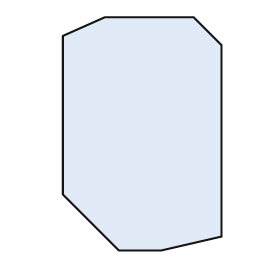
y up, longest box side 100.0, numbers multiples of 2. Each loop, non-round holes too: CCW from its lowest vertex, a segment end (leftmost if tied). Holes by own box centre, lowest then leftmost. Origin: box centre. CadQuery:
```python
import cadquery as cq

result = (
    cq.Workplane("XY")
    .moveTo(-10.0, -50.0)
    .lineTo(8.0, -50.0)
    .lineTo(34.0, -44.0)
    .lineTo(34.0, 38.0)
    .lineTo(22.0, 50.0)
    .lineTo(-16.0, 50.0)
    .lineTo(-34.0, 42.0)
    .lineTo(-34.0, -26.0)
    .close()
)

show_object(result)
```